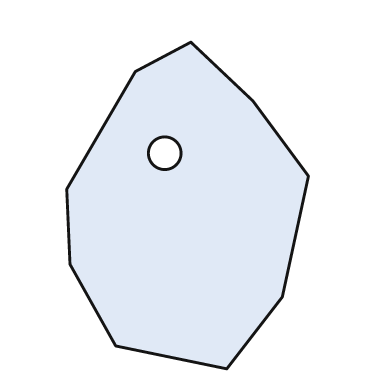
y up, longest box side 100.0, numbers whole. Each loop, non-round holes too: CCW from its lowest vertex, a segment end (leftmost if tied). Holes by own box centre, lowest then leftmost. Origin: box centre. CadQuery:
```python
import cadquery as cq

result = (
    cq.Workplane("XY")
    .moveTo(12.0, -50.0)
    .lineTo(29.0, -28.0)
    .lineTo(37.0, 9.0)
    .lineTo(20.0, 32.0)
    .lineTo(1.0, 50.0)
    .lineTo(-16.0, 41.0)
    .lineTo(-37.0, 5.0)
    .lineTo(-36.0, -18.0)
    .lineTo(-22.0, -43.0)
    .close()
    .moveTo(-7.0, 16.0)
    .circle(5.0)
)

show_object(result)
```